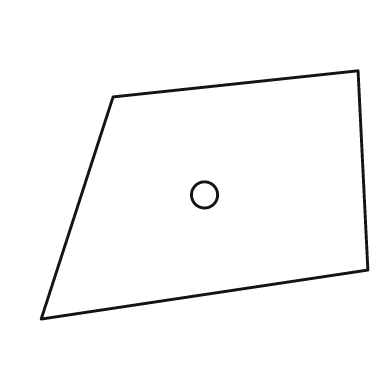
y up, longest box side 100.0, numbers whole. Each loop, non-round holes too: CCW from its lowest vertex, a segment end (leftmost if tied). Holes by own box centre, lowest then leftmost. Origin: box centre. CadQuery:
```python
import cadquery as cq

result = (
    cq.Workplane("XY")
    .moveTo(-50.0, -38.0)
    .lineTo(50.0, -23.0)
    .lineTo(47.0, 38.0)
    .lineTo(-28.0, 30.0)
    .close()
    .moveTo(0.0, 0.0)
    .circle(4.0)
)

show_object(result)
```